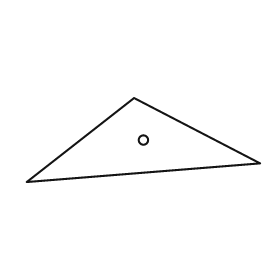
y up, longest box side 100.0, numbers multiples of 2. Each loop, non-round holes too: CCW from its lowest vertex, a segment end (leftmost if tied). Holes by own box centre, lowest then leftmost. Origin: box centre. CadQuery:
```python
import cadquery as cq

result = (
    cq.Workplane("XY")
    .moveTo(-50.0, -18.0)
    .lineTo(50.0, -10.0)
    .lineTo(-4.0, 18.0)
    .close()
    .moveTo(0.0, 0.0)
    .circle(2.0)
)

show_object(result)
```